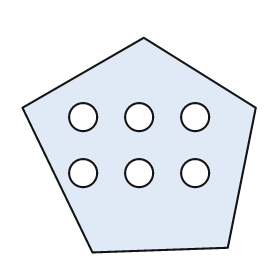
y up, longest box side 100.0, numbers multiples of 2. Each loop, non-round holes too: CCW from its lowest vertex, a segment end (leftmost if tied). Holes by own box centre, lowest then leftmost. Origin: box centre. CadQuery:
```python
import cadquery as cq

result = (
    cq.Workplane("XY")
    .moveTo(-20.0, -46.0)
    .lineTo(38.0, -44.0)
    .lineTo(50.0, 16.0)
    .lineTo(2.0, 46.0)
    .lineTo(-50.0, 16.0)
    .close()
    .moveTo(-24.0, -12.0)
    .circle(6.0)
    .moveTo(0.0, -12.0)
    .circle(6.0)
    .moveTo(24.0, -12.0)
    .circle(6.0)
    .moveTo(-24.0, 12.0)
    .circle(6.0)
    .moveTo(0.0, 12.0)
    .circle(6.0)
    .moveTo(24.0, 12.0)
    .circle(6.0)
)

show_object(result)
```